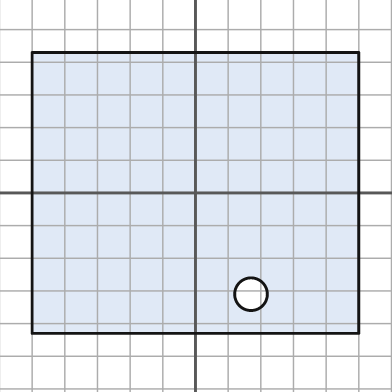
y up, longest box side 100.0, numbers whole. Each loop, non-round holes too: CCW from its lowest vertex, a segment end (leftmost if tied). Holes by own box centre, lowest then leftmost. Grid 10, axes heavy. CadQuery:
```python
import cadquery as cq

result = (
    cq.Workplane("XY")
    .moveTo(-50.0, -43.0)
    .lineTo(50.0, -43.0)
    .lineTo(50.0, 43.0)
    .lineTo(-50.0, 43.0)
    .close()
    .moveTo(17.0, -31.0)
    .circle(5.0)
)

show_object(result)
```